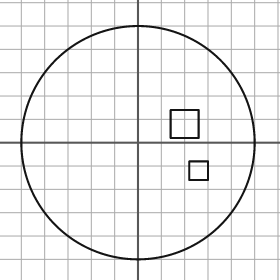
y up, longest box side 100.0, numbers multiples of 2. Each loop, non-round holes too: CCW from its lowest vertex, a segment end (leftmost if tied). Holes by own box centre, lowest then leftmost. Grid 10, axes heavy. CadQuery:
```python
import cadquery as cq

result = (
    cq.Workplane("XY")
    .moveTo(0.0, 0.0)
    .circle(50.0)
    .moveTo(22.0, -16.0)
    .lineTo(30.0, -16.0)
    .lineTo(30.0, -8.0)
    .lineTo(22.0, -8.0)
    .close()
    .moveTo(14.0, 2.0)
    .lineTo(26.0, 2.0)
    .lineTo(26.0, 14.0)
    .lineTo(14.0, 14.0)
    .close()
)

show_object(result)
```